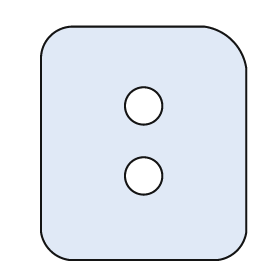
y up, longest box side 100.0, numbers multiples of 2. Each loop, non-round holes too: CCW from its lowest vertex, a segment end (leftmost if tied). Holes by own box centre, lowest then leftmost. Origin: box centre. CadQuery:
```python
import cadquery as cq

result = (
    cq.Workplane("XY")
    .moveTo(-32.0, -50.0)
    .lineTo(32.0, -50.0)
    .threePointArc((40.0, -46.0), (44.0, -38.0))
    .lineTo(44.0, 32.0)
    .threePointArc((38.0, 44.0), (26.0, 50.0))
    .lineTo(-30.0, 50.0)
    .threePointArc((-40.0, 46.0), (-44.0, 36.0))
    .lineTo(-44.0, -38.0)
    .threePointArc((-40.0, -46.0), (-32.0, -50.0))
    .close()
    .moveTo(0.0, -14.0)
    .circle(8.0)
    .moveTo(0.0, 16.0)
    .circle(8.0)
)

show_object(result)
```